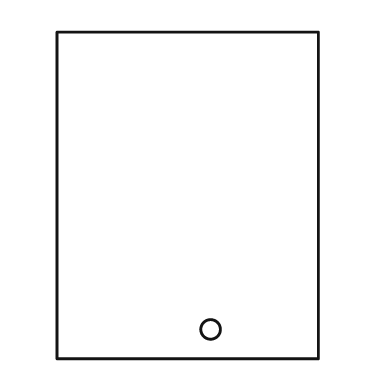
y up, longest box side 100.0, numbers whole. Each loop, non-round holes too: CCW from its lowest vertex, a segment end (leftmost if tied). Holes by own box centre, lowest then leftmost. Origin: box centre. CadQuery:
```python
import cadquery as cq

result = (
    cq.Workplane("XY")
    .moveTo(-40.0, -50.0)
    .lineTo(40.0, -50.0)
    .lineTo(40.0, 50.0)
    .lineTo(-40.0, 50.0)
    .close()
    .moveTo(7.0, -41.0)
    .circle(3.0)
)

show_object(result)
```